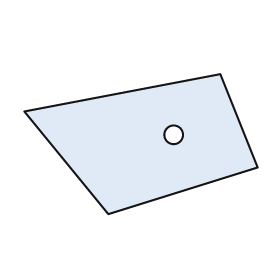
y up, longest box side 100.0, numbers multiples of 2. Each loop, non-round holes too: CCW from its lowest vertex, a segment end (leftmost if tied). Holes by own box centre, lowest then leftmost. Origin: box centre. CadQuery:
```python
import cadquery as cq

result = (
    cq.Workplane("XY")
    .moveTo(-14.0, -30.0)
    .lineTo(50.0, -10.0)
    .lineTo(34.0, 30.0)
    .lineTo(-50.0, 14.0)
    .close()
    .moveTo(14.0, 4.0)
    .circle(4.0)
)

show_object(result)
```